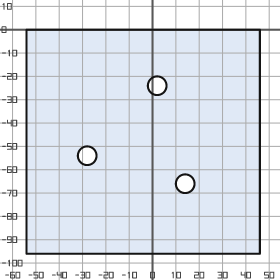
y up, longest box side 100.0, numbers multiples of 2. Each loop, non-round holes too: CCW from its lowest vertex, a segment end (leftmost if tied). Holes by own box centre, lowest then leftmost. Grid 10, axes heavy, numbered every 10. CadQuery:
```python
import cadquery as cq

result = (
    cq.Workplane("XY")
    .moveTo(-54.0, -96.0)
    .lineTo(46.0, -96.0)
    .lineTo(46.0, 0.0)
    .lineTo(-54.0, 0.0)
    .close()
    .moveTo(14.0, -66.0)
    .circle(4.0)
    .moveTo(-28.0, -54.0)
    .circle(4.0)
    .moveTo(2.0, -24.0)
    .circle(4.0)
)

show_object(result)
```